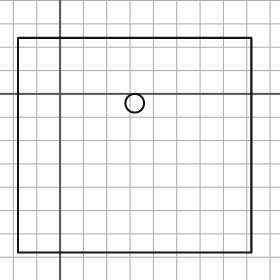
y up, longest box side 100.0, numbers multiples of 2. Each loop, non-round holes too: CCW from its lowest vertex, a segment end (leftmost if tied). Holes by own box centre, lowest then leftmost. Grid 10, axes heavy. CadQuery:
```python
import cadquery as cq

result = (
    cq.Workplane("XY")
    .moveTo(-18.0, -68.0)
    .lineTo(82.0, -68.0)
    .lineTo(82.0, 24.0)
    .lineTo(-18.0, 24.0)
    .close()
    .moveTo(32.0, -4.0)
    .circle(4.0)
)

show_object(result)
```